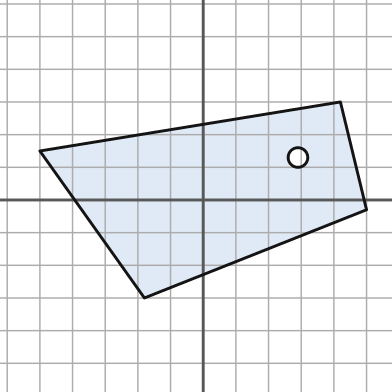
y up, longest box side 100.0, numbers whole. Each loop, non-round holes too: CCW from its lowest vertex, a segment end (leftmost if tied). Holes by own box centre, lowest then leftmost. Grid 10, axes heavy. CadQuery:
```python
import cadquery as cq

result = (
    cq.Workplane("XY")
    .moveTo(-18.0, -30.0)
    .lineTo(50.0, -3.0)
    .lineTo(42.0, 30.0)
    .lineTo(-50.0, 15.0)
    .close()
    .moveTo(29.0, 13.0)
    .circle(3.0)
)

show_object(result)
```